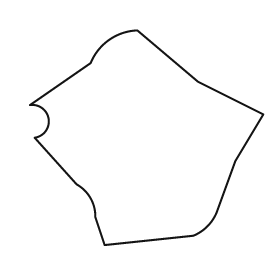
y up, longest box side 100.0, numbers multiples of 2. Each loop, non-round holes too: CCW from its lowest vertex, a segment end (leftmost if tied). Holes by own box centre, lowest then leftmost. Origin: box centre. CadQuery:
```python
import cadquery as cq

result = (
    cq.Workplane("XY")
    .moveTo(-18.0, -46.0)
    .lineTo(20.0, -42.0)
    .threePointArc((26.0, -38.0), (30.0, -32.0))
    .lineTo(38.0, -10.0)
    .lineTo(50.0, 10.0)
    .lineTo(22.0, 24.0)
    .lineTo(-4.0, 46.0)
    .threePointArc((-16.0, 42.0), (-24.0, 32.0))
    .lineTo(-50.0, 14.0)
    .threePointArc((-42.0, 8.0), (-48.0, 0.0))
    .lineTo(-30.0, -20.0)
    .threePointArc((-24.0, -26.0), (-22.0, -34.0))
    .close()
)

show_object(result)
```